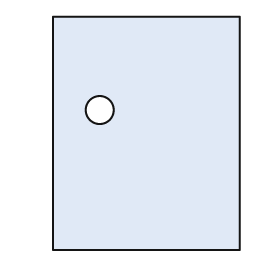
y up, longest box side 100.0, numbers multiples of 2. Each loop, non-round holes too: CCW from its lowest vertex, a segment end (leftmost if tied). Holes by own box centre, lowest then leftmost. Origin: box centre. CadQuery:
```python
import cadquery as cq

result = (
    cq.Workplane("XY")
    .moveTo(-40.0, -50.0)
    .lineTo(40.0, -50.0)
    .lineTo(40.0, 50.0)
    .lineTo(-40.0, 50.0)
    .close()
    .moveTo(-20.0, 10.0)
    .circle(6.0)
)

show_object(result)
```